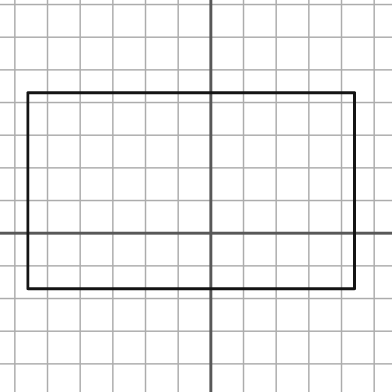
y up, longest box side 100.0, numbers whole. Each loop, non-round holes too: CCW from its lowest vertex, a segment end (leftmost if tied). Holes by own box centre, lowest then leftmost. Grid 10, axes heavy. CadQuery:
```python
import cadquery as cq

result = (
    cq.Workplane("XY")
    .moveTo(-56.0, -17.0)
    .lineTo(44.0, -17.0)
    .lineTo(44.0, 43.0)
    .lineTo(-56.0, 43.0)
    .close()
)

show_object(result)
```